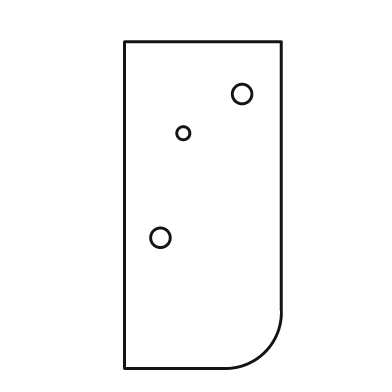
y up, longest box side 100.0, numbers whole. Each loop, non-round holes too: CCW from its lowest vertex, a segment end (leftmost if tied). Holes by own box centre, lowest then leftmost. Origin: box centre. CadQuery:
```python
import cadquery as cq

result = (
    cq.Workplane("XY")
    .moveTo(-24.0, -50.0)
    .lineTo(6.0, -50.0)
    .threePointArc((19.0, -45.0), (24.0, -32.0))
    .lineTo(24.0, 50.0)
    .lineTo(-24.0, 50.0)
    .close()
    .moveTo(-13.0, -10.0)
    .circle(3.0)
    .moveTo(-6.0, 22.0)
    .circle(2.0)
    .moveTo(12.0, 34.0)
    .circle(3.0)
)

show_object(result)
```